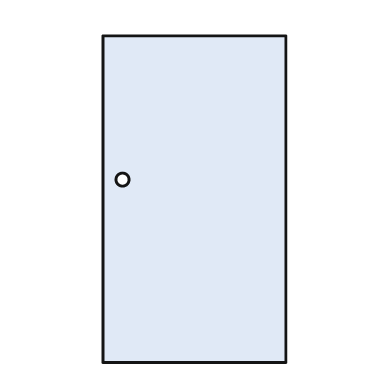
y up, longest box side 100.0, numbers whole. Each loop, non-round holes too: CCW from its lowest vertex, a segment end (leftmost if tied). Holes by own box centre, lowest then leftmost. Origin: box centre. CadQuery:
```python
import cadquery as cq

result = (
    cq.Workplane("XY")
    .moveTo(-28.0, -50.0)
    .lineTo(28.0, -50.0)
    .lineTo(28.0, 50.0)
    .lineTo(-28.0, 50.0)
    .close()
    .moveTo(-22.0, 6.0)
    .circle(2.0)
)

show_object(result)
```